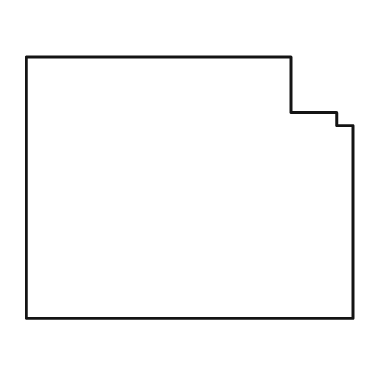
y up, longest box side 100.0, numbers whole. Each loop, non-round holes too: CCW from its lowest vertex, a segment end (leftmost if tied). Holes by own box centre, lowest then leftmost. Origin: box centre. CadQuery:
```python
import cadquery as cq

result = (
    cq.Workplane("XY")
    .moveTo(-50.0, -40.0)
    .lineTo(50.0, -40.0)
    .lineTo(50.0, 19.0)
    .lineTo(45.0, 19.0)
    .lineTo(45.0, 23.0)
    .lineTo(31.0, 23.0)
    .lineTo(31.0, 40.0)
    .lineTo(-50.0, 40.0)
    .close()
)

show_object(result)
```